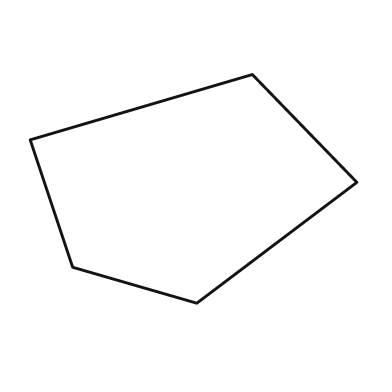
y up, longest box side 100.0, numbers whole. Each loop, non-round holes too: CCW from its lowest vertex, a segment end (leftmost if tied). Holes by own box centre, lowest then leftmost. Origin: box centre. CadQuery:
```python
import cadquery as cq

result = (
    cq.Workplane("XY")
    .moveTo(1.0, -35.0)
    .lineTo(50.0, 2.0)
    .lineTo(18.0, 35.0)
    .lineTo(-50.0, 15.0)
    .lineTo(-37.0, -24.0)
    .close()
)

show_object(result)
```